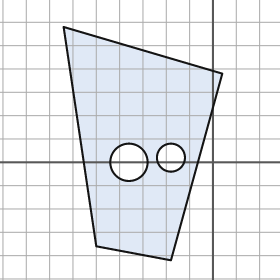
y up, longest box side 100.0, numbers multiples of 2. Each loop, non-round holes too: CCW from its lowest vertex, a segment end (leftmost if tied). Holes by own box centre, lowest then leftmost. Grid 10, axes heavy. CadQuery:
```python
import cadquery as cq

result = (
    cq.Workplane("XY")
    .moveTo(-18.0, -42.0)
    .lineTo(4.0, 38.0)
    .lineTo(-64.0, 58.0)
    .lineTo(-50.0, -36.0)
    .close()
    .moveTo(-36.0, 0.0)
    .circle(8.0)
    .moveTo(-18.0, 2.0)
    .circle(6.0)
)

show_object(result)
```